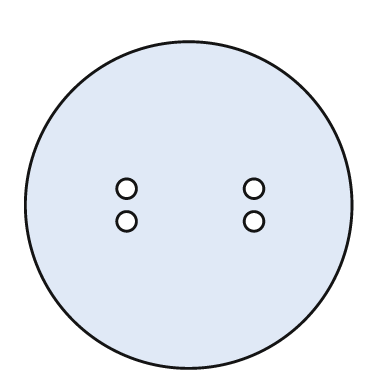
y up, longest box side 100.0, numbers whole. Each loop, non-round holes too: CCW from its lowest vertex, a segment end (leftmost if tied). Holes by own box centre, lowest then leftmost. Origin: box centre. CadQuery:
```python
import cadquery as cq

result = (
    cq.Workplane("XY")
    .moveTo(0.0, 0.0)
    .circle(50.0)
    .moveTo(-19.0, -5.0)
    .circle(3.0)
    .moveTo(20.0, -5.0)
    .circle(3.0)
    .moveTo(-19.0, 5.0)
    .circle(3.0)
    .moveTo(20.0, 5.0)
    .circle(3.0)
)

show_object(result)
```